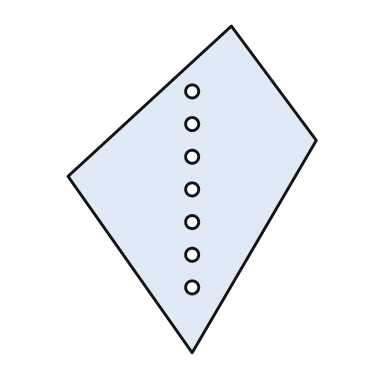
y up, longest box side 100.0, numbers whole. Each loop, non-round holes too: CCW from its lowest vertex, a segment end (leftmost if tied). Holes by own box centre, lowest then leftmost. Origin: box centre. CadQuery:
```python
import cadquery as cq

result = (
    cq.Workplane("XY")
    .moveTo(0.0, -50.0)
    .lineTo(38.0, 15.0)
    .lineTo(12.0, 50.0)
    .lineTo(-38.0, 4.0)
    .close()
    .moveTo(0.0, -30.0)
    .circle(2.0)
    .moveTo(0.0, -20.0)
    .circle(2.0)
    .moveTo(0.0, -10.0)
    .circle(2.0)
    .moveTo(0.0, 0.0)
    .circle(2.0)
    .moveTo(0.0, 10.0)
    .circle(2.0)
    .moveTo(0.0, 20.0)
    .circle(2.0)
    .moveTo(0.0, 30.0)
    .circle(2.0)
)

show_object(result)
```